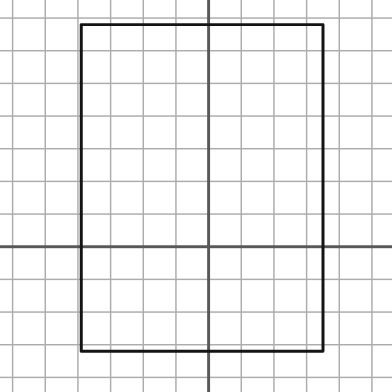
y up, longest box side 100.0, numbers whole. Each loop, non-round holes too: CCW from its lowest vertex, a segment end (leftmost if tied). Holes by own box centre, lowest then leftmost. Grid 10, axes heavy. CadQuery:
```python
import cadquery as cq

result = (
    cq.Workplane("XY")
    .moveTo(-39.0, -32.0)
    .lineTo(35.0, -32.0)
    .lineTo(35.0, 68.0)
    .lineTo(-39.0, 68.0)
    .close()
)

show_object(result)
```